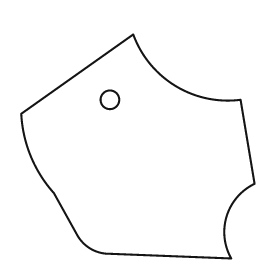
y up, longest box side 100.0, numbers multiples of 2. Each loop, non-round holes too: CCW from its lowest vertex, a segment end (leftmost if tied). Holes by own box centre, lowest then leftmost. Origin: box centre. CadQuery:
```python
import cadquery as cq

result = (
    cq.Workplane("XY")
    .moveTo(40.0, -48.0)
    .threePointArc((38.0, -30.0), (50.0, -16.0))
    .lineTo(44.0, 20.0)
    .threePointArc((16.0, 26.0), (-2.0, 48.0))
    .lineTo(-50.0, 14.0)
    .threePointArc((-46.0, -4.0), (-36.0, -20.0))
    .lineTo(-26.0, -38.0)
    .threePointArc((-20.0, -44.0), (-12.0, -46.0))
    .close()
    .moveTo(-12.0, 20.0)
    .circle(4.0)
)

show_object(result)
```